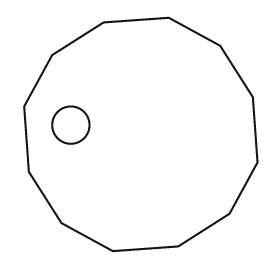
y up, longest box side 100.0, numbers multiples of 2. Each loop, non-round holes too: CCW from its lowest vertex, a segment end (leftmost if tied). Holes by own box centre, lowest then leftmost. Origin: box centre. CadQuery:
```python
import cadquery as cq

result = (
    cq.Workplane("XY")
    .moveTo(-12.0, -50.0)
    .lineTo(16.0, -48.0)
    .lineTo(38.0, -34.0)
    .lineTo(50.0, -12.0)
    .lineTo(48.0, 16.0)
    .lineTo(34.0, 38.0)
    .lineTo(12.0, 50.0)
    .lineTo(-16.0, 48.0)
    .lineTo(-38.0, 34.0)
    .lineTo(-50.0, 12.0)
    .lineTo(-48.0, -16.0)
    .lineTo(-34.0, -38.0)
    .close()
    .moveTo(-30.0, 4.0)
    .circle(8.0)
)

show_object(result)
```